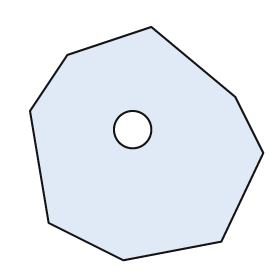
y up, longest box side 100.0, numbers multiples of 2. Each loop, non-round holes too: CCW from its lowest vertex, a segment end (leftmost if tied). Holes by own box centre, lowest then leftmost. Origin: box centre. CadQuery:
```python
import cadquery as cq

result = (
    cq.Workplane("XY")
    .moveTo(-10.0, -50.0)
    .lineTo(32.0, -42.0)
    .lineTo(50.0, -4.0)
    .lineTo(38.0, 20.0)
    .lineTo(2.0, 50.0)
    .lineTo(-34.0, 38.0)
    .lineTo(-50.0, 14.0)
    .lineTo(-42.0, -34.0)
    .close()
    .moveTo(-6.0, 6.0)
    .circle(8.0)
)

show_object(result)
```